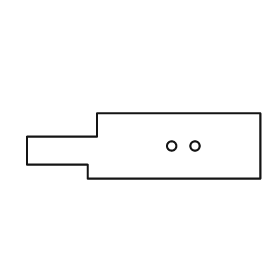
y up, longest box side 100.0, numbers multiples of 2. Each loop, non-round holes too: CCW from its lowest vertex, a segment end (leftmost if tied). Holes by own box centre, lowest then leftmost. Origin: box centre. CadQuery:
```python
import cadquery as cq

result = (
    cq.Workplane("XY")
    .moveTo(-24.0, -14.0)
    .lineTo(50.0, -14.0)
    .lineTo(50.0, 14.0)
    .lineTo(-20.0, 14.0)
    .lineTo(-20.0, 4.0)
    .lineTo(-50.0, 4.0)
    .lineTo(-50.0, -8.0)
    .lineTo(-24.0, -8.0)
    .close()
    .moveTo(12.0, 0.0)
    .circle(2.0)
    .moveTo(22.0, 0.0)
    .circle(2.0)
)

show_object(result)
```